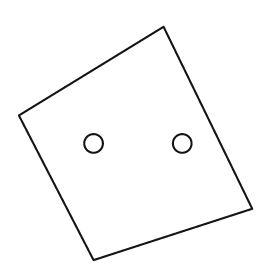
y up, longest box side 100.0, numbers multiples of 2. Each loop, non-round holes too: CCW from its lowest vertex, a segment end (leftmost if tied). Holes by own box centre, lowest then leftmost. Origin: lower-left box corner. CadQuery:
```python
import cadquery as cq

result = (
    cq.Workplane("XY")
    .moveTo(32.0, 0.0)
    .lineTo(100.0, 22.0)
    .lineTo(62.0, 100.0)
    .lineTo(0.0, 62.0)
    .close()
    .moveTo(32.0, 50.0)
    .circle(4.0)
    .moveTo(70.0, 50.0)
    .circle(4.0)
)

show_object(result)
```